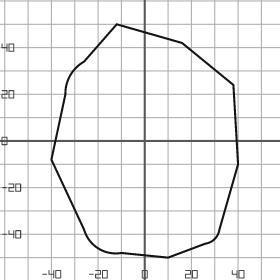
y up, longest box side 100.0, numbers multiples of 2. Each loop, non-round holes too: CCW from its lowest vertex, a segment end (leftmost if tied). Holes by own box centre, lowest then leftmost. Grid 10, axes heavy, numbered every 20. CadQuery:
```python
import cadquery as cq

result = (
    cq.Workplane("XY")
    .moveTo(10.0, -50.0)
    .lineTo(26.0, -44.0)
    .threePointArc((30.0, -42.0), (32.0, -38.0))
    .lineTo(40.0, -10.0)
    .lineTo(38.0, 24.0)
    .lineTo(16.0, 42.0)
    .lineTo(-12.0, 50.0)
    .lineTo(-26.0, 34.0)
    .threePointArc((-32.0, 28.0), (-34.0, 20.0))
    .lineTo(-40.0, -8.0)
    .lineTo(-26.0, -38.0)
    .threePointArc((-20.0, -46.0), (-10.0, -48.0))
    .close()
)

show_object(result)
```